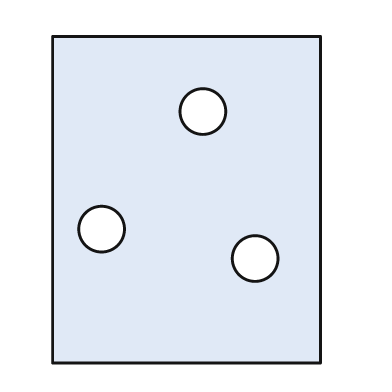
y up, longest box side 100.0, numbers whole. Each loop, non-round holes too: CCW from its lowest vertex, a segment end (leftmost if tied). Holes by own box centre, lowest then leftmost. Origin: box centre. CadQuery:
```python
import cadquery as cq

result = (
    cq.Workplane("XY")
    .moveTo(-41.0, -50.0)
    .lineTo(41.0, -50.0)
    .lineTo(41.0, 50.0)
    .lineTo(-41.0, 50.0)
    .close()
    .moveTo(21.0, -18.0)
    .circle(7.0)
    .moveTo(-26.0, -9.0)
    .circle(7.0)
    .moveTo(5.0, 27.0)
    .circle(7.0)
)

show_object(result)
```